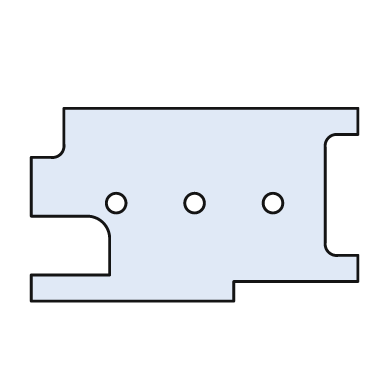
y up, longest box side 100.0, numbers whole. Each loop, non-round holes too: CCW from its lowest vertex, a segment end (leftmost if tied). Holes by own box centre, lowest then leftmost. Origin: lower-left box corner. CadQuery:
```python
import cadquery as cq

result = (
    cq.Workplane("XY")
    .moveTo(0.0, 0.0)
    .lineTo(62.0, 0.0)
    .lineTo(62.0, 6.0)
    .lineTo(100.0, 6.0)
    .lineTo(100.0, 14.0)
    .lineTo(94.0, 14.0)
    .threePointArc((91.0, 15.0), (90.0, 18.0))
    .lineTo(90.0, 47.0)
    .threePointArc((91.0, 50.0), (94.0, 51.0))
    .lineTo(100.0, 51.0)
    .lineTo(100.0, 59.0)
    .lineTo(10.0, 59.0)
    .lineTo(10.0, 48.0)
    .threePointArc((9.0, 45.0), (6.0, 44.0))
    .lineTo(0.0, 44.0)
    .lineTo(0.0, 26.0)
    .lineTo(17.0, 26.0)
    .threePointArc((22.0, 24.0), (24.0, 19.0))
    .lineTo(24.0, 8.0)
    .lineTo(0.0, 8.0)
    .close()
    .moveTo(26.0, 30.0)
    .circle(3.0)
    .moveTo(50.0, 30.0)
    .circle(3.0)
    .moveTo(74.0, 30.0)
    .circle(3.0)
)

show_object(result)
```